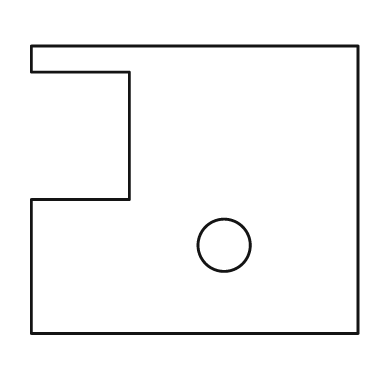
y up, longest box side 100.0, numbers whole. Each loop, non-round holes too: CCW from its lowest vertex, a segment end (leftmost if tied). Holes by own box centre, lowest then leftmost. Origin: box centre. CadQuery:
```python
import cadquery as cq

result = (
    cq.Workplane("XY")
    .moveTo(-50.0, -44.0)
    .lineTo(50.0, -44.0)
    .lineTo(50.0, 44.0)
    .lineTo(-50.0, 44.0)
    .lineTo(-50.0, 36.0)
    .lineTo(-20.0, 36.0)
    .lineTo(-20.0, -3.0)
    .lineTo(-50.0, -3.0)
    .close()
    .moveTo(9.0, -17.0)
    .circle(8.0)
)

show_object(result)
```